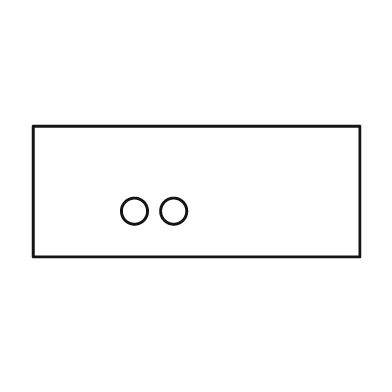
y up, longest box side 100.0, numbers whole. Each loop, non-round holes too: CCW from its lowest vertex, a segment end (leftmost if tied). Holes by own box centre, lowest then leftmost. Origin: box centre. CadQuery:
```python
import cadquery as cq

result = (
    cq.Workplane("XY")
    .moveTo(-50.0, -20.0)
    .lineTo(50.0, -20.0)
    .lineTo(50.0, 20.0)
    .lineTo(-50.0, 20.0)
    .close()
    .moveTo(-19.0, -6.0)
    .circle(4.0)
    .moveTo(-7.0, -6.0)
    .circle(4.0)
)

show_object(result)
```